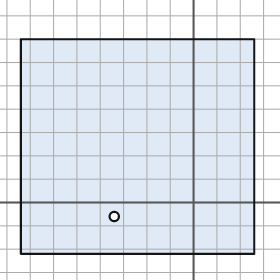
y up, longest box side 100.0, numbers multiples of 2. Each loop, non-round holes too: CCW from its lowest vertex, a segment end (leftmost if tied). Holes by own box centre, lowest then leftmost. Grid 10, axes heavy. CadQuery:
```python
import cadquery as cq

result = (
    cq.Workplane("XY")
    .moveTo(-74.0, -22.0)
    .lineTo(26.0, -22.0)
    .lineTo(26.0, 70.0)
    .lineTo(-74.0, 70.0)
    .close()
    .moveTo(-34.0, -6.0)
    .circle(2.0)
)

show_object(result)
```